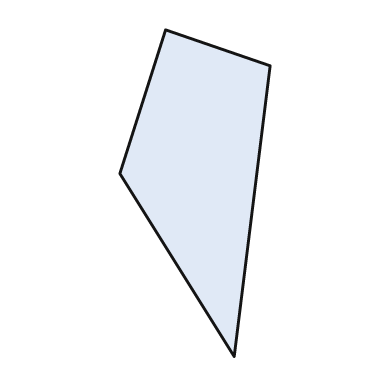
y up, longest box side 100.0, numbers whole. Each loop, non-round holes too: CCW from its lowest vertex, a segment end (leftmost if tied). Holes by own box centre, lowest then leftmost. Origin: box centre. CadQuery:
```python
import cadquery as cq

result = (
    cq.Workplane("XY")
    .moveTo(12.0, -50.0)
    .lineTo(23.0, 39.0)
    .lineTo(-9.0, 50.0)
    .lineTo(-23.0, 6.0)
    .close()
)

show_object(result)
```